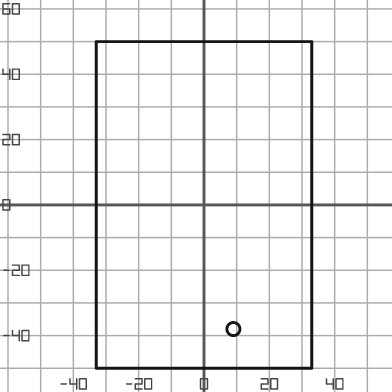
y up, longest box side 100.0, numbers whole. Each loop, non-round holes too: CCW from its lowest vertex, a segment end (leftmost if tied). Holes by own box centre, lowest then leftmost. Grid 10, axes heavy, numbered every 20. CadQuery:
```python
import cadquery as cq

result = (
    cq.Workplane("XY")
    .moveTo(-33.0, -50.0)
    .lineTo(33.0, -50.0)
    .lineTo(33.0, 50.0)
    .lineTo(-33.0, 50.0)
    .close()
    .moveTo(9.0, -38.0)
    .circle(2.0)
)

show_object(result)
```